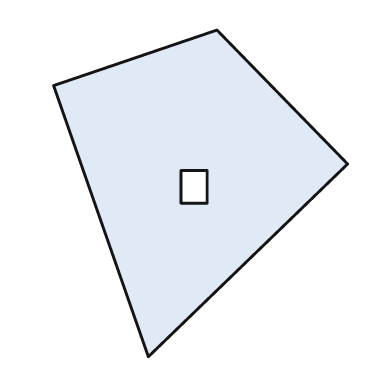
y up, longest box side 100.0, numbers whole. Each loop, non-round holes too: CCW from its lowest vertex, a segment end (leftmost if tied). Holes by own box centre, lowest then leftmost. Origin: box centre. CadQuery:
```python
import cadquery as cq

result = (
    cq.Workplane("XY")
    .moveTo(-16.0, -50.0)
    .lineTo(45.0, 9.0)
    .lineTo(5.0, 50.0)
    .lineTo(-45.0, 33.0)
    .close()
    .moveTo(-6.0, -3.0)
    .lineTo(2.0, -3.0)
    .lineTo(2.0, 7.0)
    .lineTo(-6.0, 7.0)
    .close()
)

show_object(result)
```